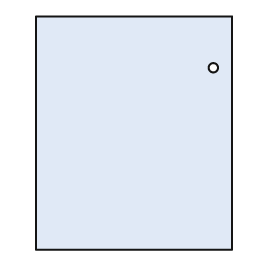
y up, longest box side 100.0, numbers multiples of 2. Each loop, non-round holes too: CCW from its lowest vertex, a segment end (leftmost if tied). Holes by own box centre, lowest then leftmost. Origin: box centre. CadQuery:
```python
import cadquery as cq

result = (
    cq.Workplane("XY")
    .moveTo(-42.0, -50.0)
    .lineTo(42.0, -50.0)
    .lineTo(42.0, 50.0)
    .lineTo(-42.0, 50.0)
    .close()
    .moveTo(34.0, 28.0)
    .circle(2.0)
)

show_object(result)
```